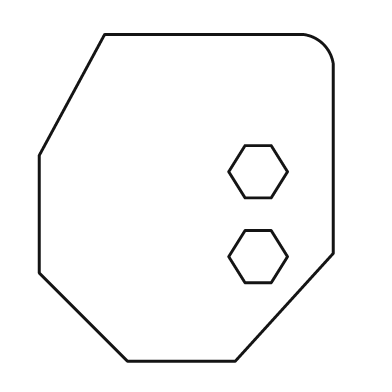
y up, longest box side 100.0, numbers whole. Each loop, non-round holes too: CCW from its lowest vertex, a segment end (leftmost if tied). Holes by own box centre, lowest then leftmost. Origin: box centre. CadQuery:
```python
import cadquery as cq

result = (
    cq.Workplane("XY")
    .moveTo(-18.0, -50.0)
    .lineTo(15.0, -50.0)
    .lineTo(45.0, -17.0)
    .lineTo(45.0, 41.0)
    .threePointArc((42.0, 47.0), (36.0, 50.0))
    .lineTo(-25.0, 50.0)
    .lineTo(-45.0, 13.0)
    .lineTo(-45.0, -23.0)
    .close()
    .moveTo(18.0, -26.0)
    .lineTo(26.0, -26.0)
    .lineTo(31.0, -18.0)
    .lineTo(26.0, -10.0)
    .lineTo(18.0, -10.0)
    .lineTo(13.0, -18.0)
    .close()
    .moveTo(18.0, 0.0)
    .lineTo(26.0, 0.0)
    .lineTo(31.0, 8.0)
    .lineTo(26.0, 16.0)
    .lineTo(18.0, 16.0)
    .lineTo(13.0, 8.0)
    .close()
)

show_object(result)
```